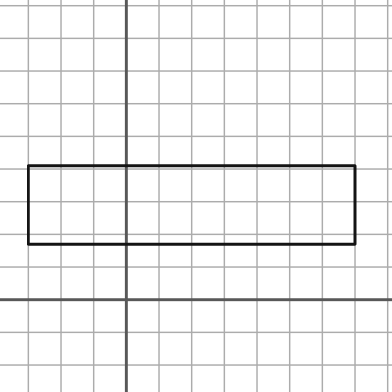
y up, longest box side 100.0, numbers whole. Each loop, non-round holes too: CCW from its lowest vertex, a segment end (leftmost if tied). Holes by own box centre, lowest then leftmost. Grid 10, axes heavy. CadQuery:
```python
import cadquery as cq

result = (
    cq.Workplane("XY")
    .moveTo(-30.0, 17.0)
    .lineTo(70.0, 17.0)
    .lineTo(70.0, 41.0)
    .lineTo(-30.0, 41.0)
    .close()
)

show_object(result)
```